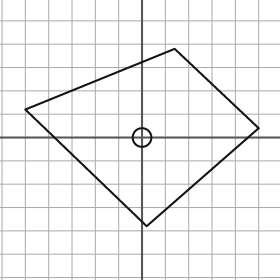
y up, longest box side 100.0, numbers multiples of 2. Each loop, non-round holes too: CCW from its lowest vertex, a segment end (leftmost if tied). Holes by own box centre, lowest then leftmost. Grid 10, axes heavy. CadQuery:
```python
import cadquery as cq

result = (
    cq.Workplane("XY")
    .moveTo(2.0, -38.0)
    .lineTo(50.0, 4.0)
    .lineTo(14.0, 38.0)
    .lineTo(-50.0, 12.0)
    .close()
    .moveTo(0.0, 0.0)
    .circle(4.0)
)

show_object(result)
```